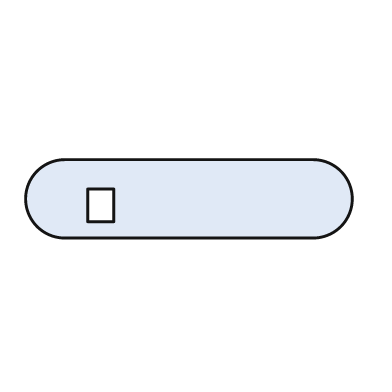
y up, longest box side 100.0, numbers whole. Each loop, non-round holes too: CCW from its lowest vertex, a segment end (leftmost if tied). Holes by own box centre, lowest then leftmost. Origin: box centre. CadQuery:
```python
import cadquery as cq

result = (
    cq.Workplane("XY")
    .moveTo(-38.0, -12.0)
    .lineTo(38.0, -12.0)
    .threePointArc((50.0, 0.0), (38.0, 12.0))
    .lineTo(-38.0, 12.0)
    .threePointArc((-50.0, 0.0), (-38.0, -12.0))
    .close()
    .moveTo(-31.0, -7.0)
    .lineTo(-23.0, -7.0)
    .lineTo(-23.0, 3.0)
    .lineTo(-31.0, 3.0)
    .close()
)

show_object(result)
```